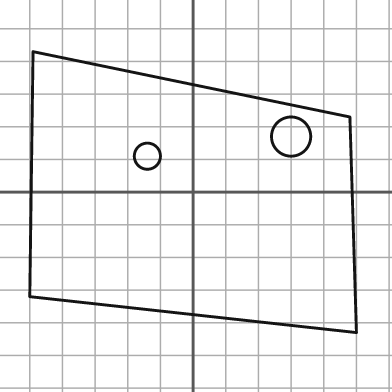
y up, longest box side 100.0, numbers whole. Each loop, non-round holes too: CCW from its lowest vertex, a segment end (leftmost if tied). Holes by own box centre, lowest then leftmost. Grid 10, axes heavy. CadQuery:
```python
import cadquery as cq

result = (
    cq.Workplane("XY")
    .moveTo(50.0, -43.0)
    .lineTo(48.0, 23.0)
    .lineTo(-49.0, 43.0)
    .lineTo(-50.0, -32.0)
    .close()
    .moveTo(-14.0, 11.0)
    .circle(4.0)
    .moveTo(30.0, 17.0)
    .circle(6.0)
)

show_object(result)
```